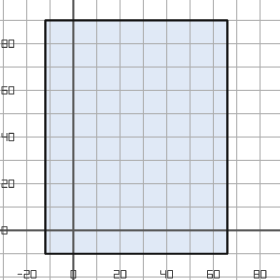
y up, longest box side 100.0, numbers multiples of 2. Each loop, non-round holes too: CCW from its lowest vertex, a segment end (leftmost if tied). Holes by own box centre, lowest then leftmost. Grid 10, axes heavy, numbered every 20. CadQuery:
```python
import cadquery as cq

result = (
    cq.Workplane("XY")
    .moveTo(-12.0, -10.0)
    .lineTo(66.0, -10.0)
    .lineTo(66.0, 90.0)
    .lineTo(-12.0, 90.0)
    .close()
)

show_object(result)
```